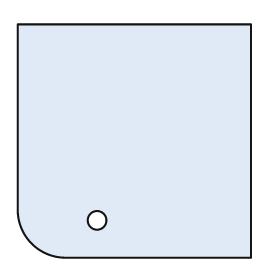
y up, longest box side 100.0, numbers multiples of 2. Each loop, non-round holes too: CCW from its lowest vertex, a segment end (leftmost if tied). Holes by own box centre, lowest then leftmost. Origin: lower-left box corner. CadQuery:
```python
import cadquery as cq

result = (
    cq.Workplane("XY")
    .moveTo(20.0, 0.0)
    .lineTo(100.0, 0.0)
    .lineTo(100.0, 100.0)
    .lineTo(0.0, 100.0)
    .lineTo(0.0, 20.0)
    .threePointArc((6.0, 6.0), (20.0, 0.0))
    .close()
    .moveTo(34.0, 16.0)
    .circle(4.0)
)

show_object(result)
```